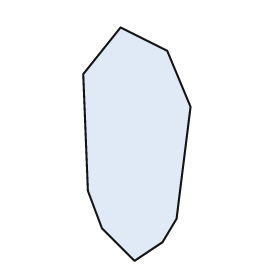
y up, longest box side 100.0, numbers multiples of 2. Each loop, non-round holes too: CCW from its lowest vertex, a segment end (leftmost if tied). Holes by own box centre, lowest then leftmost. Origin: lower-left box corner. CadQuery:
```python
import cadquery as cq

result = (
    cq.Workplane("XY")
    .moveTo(22.0, 0.0)
    .lineTo(34.0, 8.0)
    .lineTo(40.0, 18.0)
    .lineTo(46.0, 66.0)
    .lineTo(36.0, 90.0)
    .lineTo(16.0, 100.0)
    .lineTo(0.0, 80.0)
    .lineTo(2.0, 30.0)
    .lineTo(8.0, 14.0)
    .close()
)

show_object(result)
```